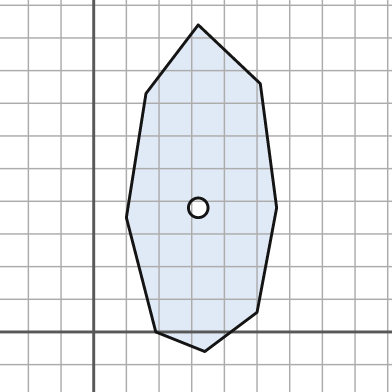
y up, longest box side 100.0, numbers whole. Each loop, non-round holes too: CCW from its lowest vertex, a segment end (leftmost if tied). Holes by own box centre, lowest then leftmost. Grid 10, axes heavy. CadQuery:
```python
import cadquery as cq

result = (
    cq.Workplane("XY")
    .moveTo(34.0, -6.0)
    .lineTo(50.0, 6.0)
    .lineTo(56.0, 38.0)
    .lineTo(51.0, 76.0)
    .lineTo(32.0, 94.0)
    .lineTo(16.0, 73.0)
    .lineTo(10.0, 35.0)
    .lineTo(19.0, 0.0)
    .close()
    .moveTo(32.0, 38.0)
    .circle(3.0)
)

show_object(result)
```